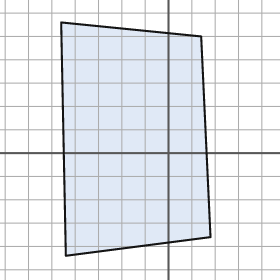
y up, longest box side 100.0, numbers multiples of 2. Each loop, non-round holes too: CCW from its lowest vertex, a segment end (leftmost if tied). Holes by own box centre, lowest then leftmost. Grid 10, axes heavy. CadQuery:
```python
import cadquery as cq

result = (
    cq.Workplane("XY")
    .moveTo(-44.0, -44.0)
    .lineTo(18.0, -36.0)
    .lineTo(14.0, 50.0)
    .lineTo(-46.0, 56.0)
    .close()
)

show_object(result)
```